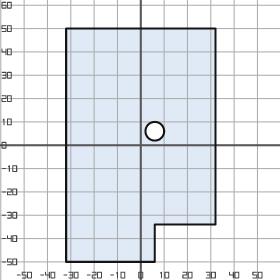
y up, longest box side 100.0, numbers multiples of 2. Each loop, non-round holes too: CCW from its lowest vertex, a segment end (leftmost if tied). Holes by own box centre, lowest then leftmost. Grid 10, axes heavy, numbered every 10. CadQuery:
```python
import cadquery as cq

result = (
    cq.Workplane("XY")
    .moveTo(-32.0, -50.0)
    .lineTo(6.0, -50.0)
    .lineTo(6.0, -34.0)
    .lineTo(32.0, -34.0)
    .lineTo(32.0, 50.0)
    .lineTo(-32.0, 50.0)
    .close()
    .moveTo(6.0, 6.0)
    .circle(4.0)
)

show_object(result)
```